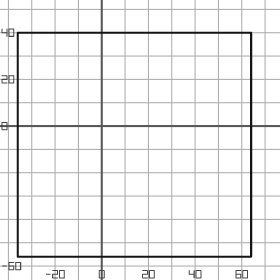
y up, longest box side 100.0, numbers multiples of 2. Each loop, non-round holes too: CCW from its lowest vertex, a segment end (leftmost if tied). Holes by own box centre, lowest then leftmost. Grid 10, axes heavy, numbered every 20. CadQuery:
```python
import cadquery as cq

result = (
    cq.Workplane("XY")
    .moveTo(-36.0, -56.0)
    .lineTo(64.0, -56.0)
    .lineTo(64.0, 40.0)
    .lineTo(-36.0, 40.0)
    .close()
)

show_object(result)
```